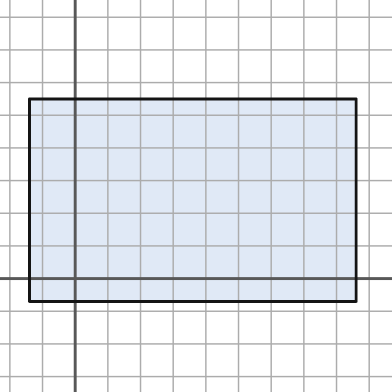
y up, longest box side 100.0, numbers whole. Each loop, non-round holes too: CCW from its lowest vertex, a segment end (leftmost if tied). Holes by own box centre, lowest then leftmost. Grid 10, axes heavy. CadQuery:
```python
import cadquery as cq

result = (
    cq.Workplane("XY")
    .moveTo(-14.0, -7.0)
    .lineTo(86.0, -7.0)
    .lineTo(86.0, 55.0)
    .lineTo(-14.0, 55.0)
    .close()
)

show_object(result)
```